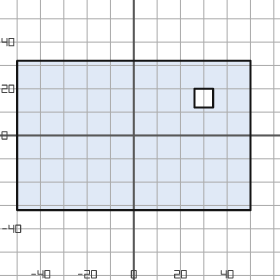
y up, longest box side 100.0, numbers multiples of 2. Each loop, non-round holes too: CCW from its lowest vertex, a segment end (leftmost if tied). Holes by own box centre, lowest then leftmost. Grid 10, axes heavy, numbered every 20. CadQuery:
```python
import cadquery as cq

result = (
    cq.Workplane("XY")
    .moveTo(-50.0, -32.0)
    .lineTo(50.0, -32.0)
    .lineTo(50.0, 32.0)
    .lineTo(-50.0, 32.0)
    .close()
    .moveTo(26.0, 12.0)
    .lineTo(34.0, 12.0)
    .lineTo(34.0, 20.0)
    .lineTo(26.0, 20.0)
    .close()
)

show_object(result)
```